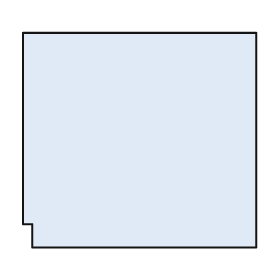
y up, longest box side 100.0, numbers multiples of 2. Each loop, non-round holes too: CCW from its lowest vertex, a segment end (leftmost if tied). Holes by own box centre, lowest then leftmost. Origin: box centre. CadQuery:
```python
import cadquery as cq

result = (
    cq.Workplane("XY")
    .moveTo(-46.0, -46.0)
    .lineTo(50.0, -46.0)
    .lineTo(50.0, 46.0)
    .lineTo(-50.0, 46.0)
    .lineTo(-50.0, -36.0)
    .lineTo(-46.0, -36.0)
    .close()
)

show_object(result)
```